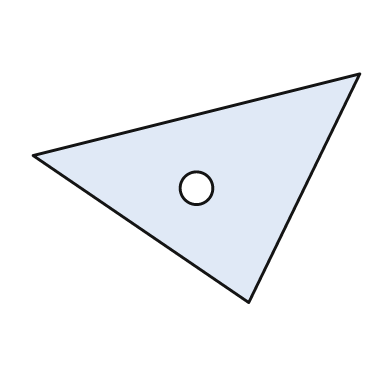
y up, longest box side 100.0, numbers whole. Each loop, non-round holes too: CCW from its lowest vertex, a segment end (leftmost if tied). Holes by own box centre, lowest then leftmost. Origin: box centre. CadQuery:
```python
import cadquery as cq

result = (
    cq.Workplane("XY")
    .moveTo(16.0, -35.0)
    .lineTo(50.0, 35.0)
    .lineTo(-50.0, 10.0)
    .close()
    .moveTo(0.0, 0.0)
    .circle(5.0)
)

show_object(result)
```